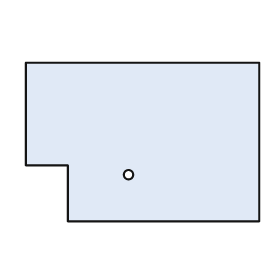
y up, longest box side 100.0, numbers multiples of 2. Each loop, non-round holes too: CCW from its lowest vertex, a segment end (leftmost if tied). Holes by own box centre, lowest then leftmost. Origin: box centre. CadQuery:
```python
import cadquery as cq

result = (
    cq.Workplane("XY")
    .moveTo(-32.0, -34.0)
    .lineTo(50.0, -34.0)
    .lineTo(50.0, 34.0)
    .lineTo(-50.0, 34.0)
    .lineTo(-50.0, -10.0)
    .lineTo(-32.0, -10.0)
    .close()
    .moveTo(-6.0, -14.0)
    .circle(2.0)
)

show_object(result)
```